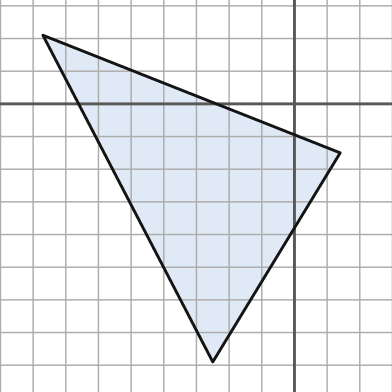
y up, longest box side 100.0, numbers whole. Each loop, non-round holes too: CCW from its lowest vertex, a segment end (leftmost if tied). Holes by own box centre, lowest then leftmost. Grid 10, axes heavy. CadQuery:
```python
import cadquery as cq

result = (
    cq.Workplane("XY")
    .moveTo(-25.0, -79.0)
    .lineTo(14.0, -15.0)
    .lineTo(-77.0, 21.0)
    .close()
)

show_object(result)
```